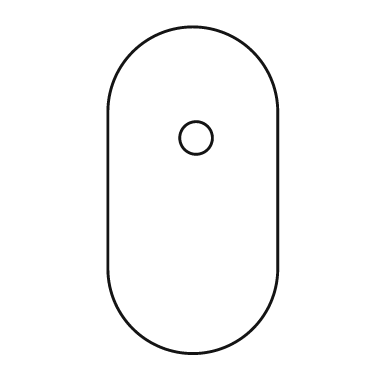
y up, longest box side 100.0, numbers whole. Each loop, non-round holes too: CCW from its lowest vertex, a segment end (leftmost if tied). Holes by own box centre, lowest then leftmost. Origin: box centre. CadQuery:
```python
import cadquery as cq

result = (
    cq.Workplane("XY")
    .moveTo(-26.0, -24.0)
    .threePointArc((0.0, -50.0), (26.0, -24.0))
    .lineTo(26.0, 24.0)
    .threePointArc((0.0, 50.0), (-26.0, 24.0))
    .close()
    .moveTo(1.0, 16.0)
    .circle(5.0)
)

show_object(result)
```